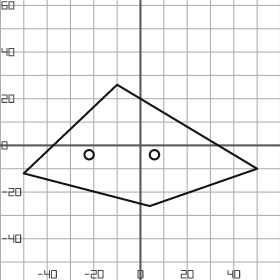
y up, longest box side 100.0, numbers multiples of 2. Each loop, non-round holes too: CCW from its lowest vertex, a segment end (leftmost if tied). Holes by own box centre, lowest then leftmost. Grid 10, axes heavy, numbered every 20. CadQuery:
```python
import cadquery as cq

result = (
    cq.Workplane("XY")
    .moveTo(4.0, -26.0)
    .lineTo(50.0, -10.0)
    .lineTo(-10.0, 26.0)
    .lineTo(-50.0, -12.0)
    .close()
    .moveTo(-22.0, -4.0)
    .circle(2.0)
    .moveTo(6.0, -4.0)
    .circle(2.0)
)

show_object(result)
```